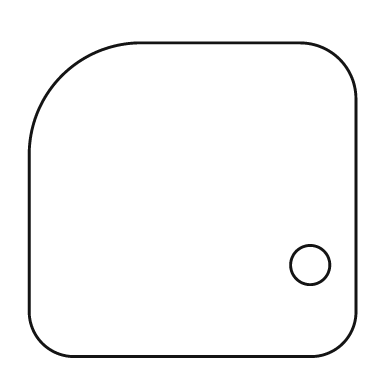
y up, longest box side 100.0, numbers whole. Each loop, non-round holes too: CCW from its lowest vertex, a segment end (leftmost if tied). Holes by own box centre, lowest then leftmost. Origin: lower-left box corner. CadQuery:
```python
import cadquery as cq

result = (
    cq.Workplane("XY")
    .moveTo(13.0, 0.0)
    .lineTo(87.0, 0.0)
    .threePointArc((96.0, 4.0), (100.0, 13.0))
    .lineTo(100.0, 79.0)
    .threePointArc((95.0, 91.0), (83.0, 96.0))
    .lineTo(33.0, 96.0)
    .threePointArc((10.0, 86.0), (0.0, 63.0))
    .lineTo(0.0, 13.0)
    .threePointArc((4.0, 4.0), (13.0, 0.0))
    .close()
    .moveTo(86.0, 28.0)
    .circle(6.0)
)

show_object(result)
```